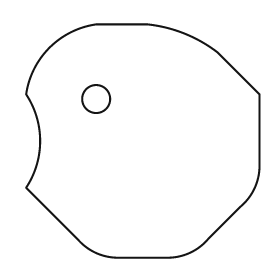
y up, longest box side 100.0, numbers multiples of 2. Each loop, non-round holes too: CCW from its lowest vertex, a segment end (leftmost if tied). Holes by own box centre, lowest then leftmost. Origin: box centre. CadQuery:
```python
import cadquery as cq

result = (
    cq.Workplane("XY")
    .moveTo(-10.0, -50.0)
    .lineTo(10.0, -50.0)
    .threePointArc((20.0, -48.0), (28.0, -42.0))
    .lineTo(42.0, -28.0)
    .threePointArc((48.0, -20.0), (50.0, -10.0))
    .lineTo(50.0, 20.0)
    .lineTo(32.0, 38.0)
    .threePointArc((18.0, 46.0), (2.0, 50.0))
    .lineTo(-20.0, 50.0)
    .threePointArc((-40.0, 40.0), (-50.0, 20.0))
    .threePointArc((-44.0, 0.0), (-50.0, -20.0))
    .lineTo(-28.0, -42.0)
    .threePointArc((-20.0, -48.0), (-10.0, -50.0))
    .close()
    .moveTo(-20.0, 18.0)
    .circle(6.0)
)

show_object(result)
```